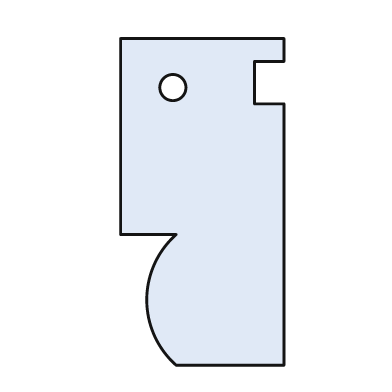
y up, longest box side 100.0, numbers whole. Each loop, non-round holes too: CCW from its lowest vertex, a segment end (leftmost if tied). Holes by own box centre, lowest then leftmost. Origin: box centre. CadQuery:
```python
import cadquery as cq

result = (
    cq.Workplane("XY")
    .moveTo(-8.0, -50.0)
    .lineTo(25.0, -50.0)
    .lineTo(25.0, 30.0)
    .lineTo(16.0, 30.0)
    .lineTo(16.0, 43.0)
    .lineTo(25.0, 43.0)
    .lineTo(25.0, 50.0)
    .lineTo(-25.0, 50.0)
    .lineTo(-25.0, -10.0)
    .lineTo(-8.0, -10.0)
    .threePointArc((-17.0, -30.0), (-8.0, -50.0))
    .close()
    .moveTo(-9.0, 35.0)
    .circle(4.0)
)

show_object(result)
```